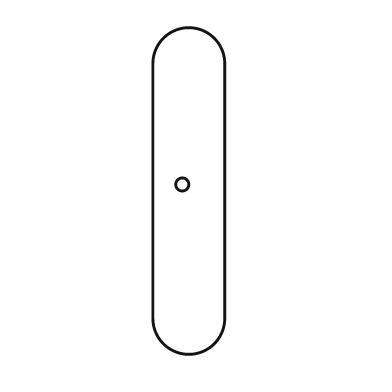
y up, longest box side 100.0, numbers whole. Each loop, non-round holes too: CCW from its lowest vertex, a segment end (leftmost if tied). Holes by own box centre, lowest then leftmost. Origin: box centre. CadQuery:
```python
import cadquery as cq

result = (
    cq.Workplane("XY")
    .moveTo(-11.0, -39.0)
    .threePointArc((0.0, -50.0), (11.0, -39.0))
    .lineTo(11.0, 39.0)
    .threePointArc((0.0, 50.0), (-11.0, 39.0))
    .close()
    .moveTo(-2.0, 2.0)
    .circle(2.0)
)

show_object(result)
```